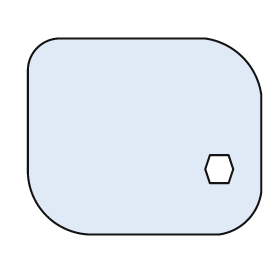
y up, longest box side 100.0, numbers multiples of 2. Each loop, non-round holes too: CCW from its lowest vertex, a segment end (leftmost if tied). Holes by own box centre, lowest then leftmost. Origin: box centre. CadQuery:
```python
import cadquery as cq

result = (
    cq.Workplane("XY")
    .moveTo(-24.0, -42.0)
    .lineTo(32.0, -42.0)
    .threePointArc((44.0, -36.0), (50.0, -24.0))
    .lineTo(50.0, 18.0)
    .threePointArc((42.0, 34.0), (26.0, 42.0))
    .lineTo(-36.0, 42.0)
    .threePointArc((-46.0, 38.0), (-50.0, 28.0))
    .lineTo(-50.0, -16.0)
    .threePointArc((-42.0, -34.0), (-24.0, -42.0))
    .close()
    .moveTo(28.0, -20.0)
    .lineTo(36.0, -20.0)
    .lineTo(38.0, -14.0)
    .lineTo(36.0, -8.0)
    .lineTo(28.0, -8.0)
    .lineTo(26.0, -14.0)
    .close()
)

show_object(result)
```